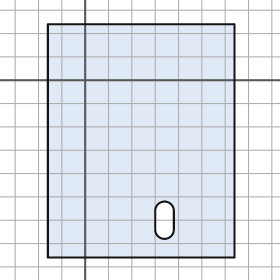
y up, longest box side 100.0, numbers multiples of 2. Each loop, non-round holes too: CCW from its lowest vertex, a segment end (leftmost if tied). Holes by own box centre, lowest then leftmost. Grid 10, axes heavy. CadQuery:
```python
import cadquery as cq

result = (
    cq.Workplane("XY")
    .moveTo(-16.0, -76.0)
    .lineTo(64.0, -76.0)
    .lineTo(64.0, 24.0)
    .lineTo(-16.0, 24.0)
    .close()
    .moveTo(30.0, -64.0)
    .threePointArc((34.0, -68.0), (38.0, -64.0))
    .lineTo(38.0, -56.0)
    .threePointArc((34.0, -52.0), (30.0, -56.0))
    .close()
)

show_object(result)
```